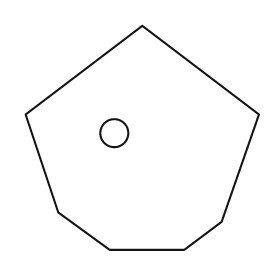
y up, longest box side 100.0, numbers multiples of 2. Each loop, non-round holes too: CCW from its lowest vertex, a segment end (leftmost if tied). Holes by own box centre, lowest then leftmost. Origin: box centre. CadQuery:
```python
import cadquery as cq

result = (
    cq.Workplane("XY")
    .moveTo(-14.0, -48.0)
    .lineTo(18.0, -48.0)
    .lineTo(34.0, -36.0)
    .lineTo(50.0, 10.0)
    .lineTo(0.0, 48.0)
    .lineTo(-50.0, 10.0)
    .lineTo(-36.0, -32.0)
    .close()
    .moveTo(-12.0, 2.0)
    .circle(6.0)
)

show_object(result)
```